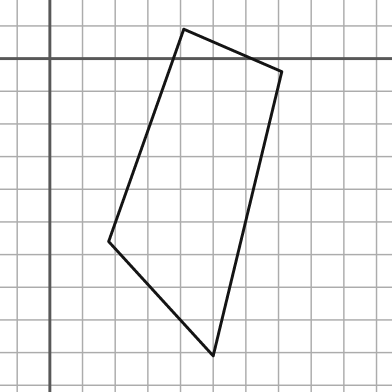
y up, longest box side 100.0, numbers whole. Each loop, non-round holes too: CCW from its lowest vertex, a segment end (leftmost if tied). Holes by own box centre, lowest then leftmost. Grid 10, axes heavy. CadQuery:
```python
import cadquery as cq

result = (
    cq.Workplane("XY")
    .moveTo(50.0, -91.0)
    .lineTo(71.0, -4.0)
    .lineTo(41.0, 9.0)
    .lineTo(18.0, -56.0)
    .close()
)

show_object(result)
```